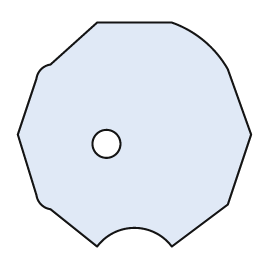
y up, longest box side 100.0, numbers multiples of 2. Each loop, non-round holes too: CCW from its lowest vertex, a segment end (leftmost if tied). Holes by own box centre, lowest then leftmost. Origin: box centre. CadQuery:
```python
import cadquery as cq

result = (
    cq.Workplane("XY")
    .moveTo(-16.0, -48.0)
    .threePointArc((0.0, -40.0), (16.0, -48.0))
    .lineTo(40.0, -30.0)
    .lineTo(50.0, 0.0)
    .lineTo(40.0, 28.0)
    .threePointArc((30.0, 40.0), (16.0, 48.0))
    .lineTo(-16.0, 48.0)
    .lineTo(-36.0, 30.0)
    .threePointArc((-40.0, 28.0), (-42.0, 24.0))
    .lineTo(-50.0, 0.0)
    .lineTo(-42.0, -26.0)
    .threePointArc((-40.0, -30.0), (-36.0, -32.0))
    .close()
    .moveTo(-12.0, -4.0)
    .circle(6.0)
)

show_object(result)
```